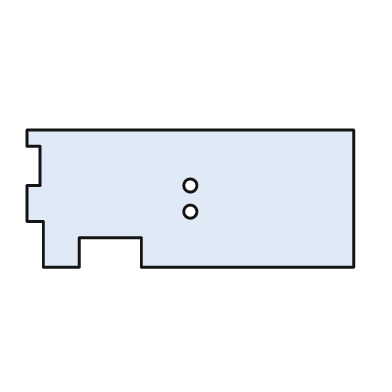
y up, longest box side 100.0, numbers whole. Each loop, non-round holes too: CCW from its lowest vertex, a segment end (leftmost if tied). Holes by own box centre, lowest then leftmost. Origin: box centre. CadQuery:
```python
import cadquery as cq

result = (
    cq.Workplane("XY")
    .moveTo(-45.0, -21.0)
    .lineTo(-34.0, -21.0)
    .lineTo(-34.0, -12.0)
    .lineTo(-15.0, -12.0)
    .lineTo(-15.0, -21.0)
    .lineTo(50.0, -21.0)
    .lineTo(50.0, 21.0)
    .lineTo(-50.0, 21.0)
    .lineTo(-50.0, 16.0)
    .lineTo(-46.0, 16.0)
    .lineTo(-46.0, 4.0)
    .lineTo(-50.0, 4.0)
    .lineTo(-50.0, -7.0)
    .lineTo(-45.0, -7.0)
    .close()
    .moveTo(0.0, -4.0)
    .circle(2.0)
    .moveTo(0.0, 4.0)
    .circle(2.0)
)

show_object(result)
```